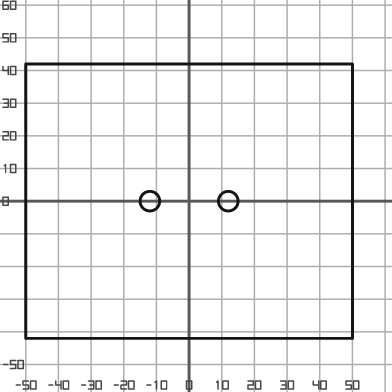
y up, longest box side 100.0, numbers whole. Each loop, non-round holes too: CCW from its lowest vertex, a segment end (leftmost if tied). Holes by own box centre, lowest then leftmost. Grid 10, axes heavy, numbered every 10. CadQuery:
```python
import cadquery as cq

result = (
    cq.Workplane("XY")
    .moveTo(-50.0, -42.0)
    .lineTo(50.0, -42.0)
    .lineTo(50.0, 42.0)
    .lineTo(-50.0, 42.0)
    .close()
    .moveTo(-12.0, 0.0)
    .circle(3.0)
    .moveTo(12.0, 0.0)
    .circle(3.0)
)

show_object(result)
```